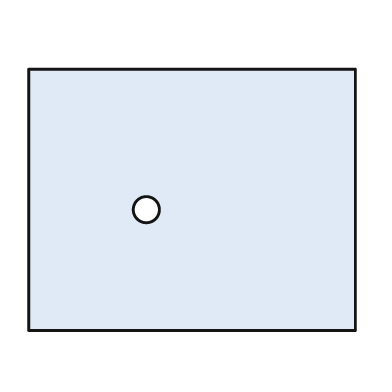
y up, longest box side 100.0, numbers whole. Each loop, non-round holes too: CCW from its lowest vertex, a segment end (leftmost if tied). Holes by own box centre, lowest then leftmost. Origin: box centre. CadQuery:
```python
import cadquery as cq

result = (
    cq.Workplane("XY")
    .moveTo(-50.0, -40.0)
    .lineTo(50.0, -40.0)
    .lineTo(50.0, 40.0)
    .lineTo(-50.0, 40.0)
    .close()
    .moveTo(-14.0, -3.0)
    .circle(4.0)
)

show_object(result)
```